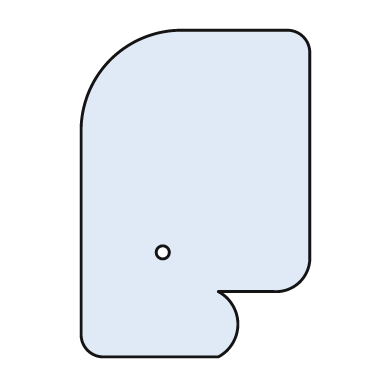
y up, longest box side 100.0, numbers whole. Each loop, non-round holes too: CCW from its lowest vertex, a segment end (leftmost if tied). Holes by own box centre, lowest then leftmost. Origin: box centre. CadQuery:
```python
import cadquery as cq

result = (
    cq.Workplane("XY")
    .moveTo(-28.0, -50.0)
    .lineTo(7.0, -50.0)
    .threePointArc((13.0, -40.0), (7.0, -30.0))
    .lineTo(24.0, -30.0)
    .threePointArc((32.0, -27.0), (35.0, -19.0))
    .lineTo(35.0, 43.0)
    .threePointArc((33.0, 48.0), (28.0, 50.0))
    .lineTo(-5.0, 50.0)
    .threePointArc((-26.0, 41.0), (-35.0, 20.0))
    .lineTo(-35.0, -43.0)
    .threePointArc((-33.0, -48.0), (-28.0, -50.0))
    .close()
    .moveTo(-10.0, -18.0)
    .circle(2.0)
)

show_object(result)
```